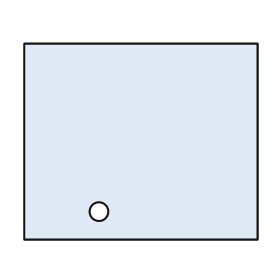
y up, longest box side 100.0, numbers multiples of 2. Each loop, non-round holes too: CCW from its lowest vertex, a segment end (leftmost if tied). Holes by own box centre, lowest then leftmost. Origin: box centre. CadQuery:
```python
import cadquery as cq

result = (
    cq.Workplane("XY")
    .moveTo(-50.0, -42.0)
    .lineTo(50.0, -42.0)
    .lineTo(50.0, 42.0)
    .lineTo(-50.0, 42.0)
    .close()
    .moveTo(-18.0, -30.0)
    .circle(4.0)
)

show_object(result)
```